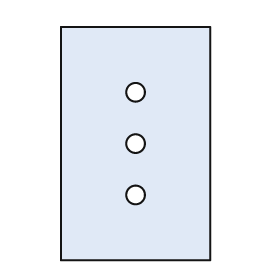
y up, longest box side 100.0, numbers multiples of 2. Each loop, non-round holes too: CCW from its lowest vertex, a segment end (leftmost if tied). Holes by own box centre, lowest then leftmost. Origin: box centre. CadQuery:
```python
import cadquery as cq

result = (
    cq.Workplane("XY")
    .moveTo(-32.0, -50.0)
    .lineTo(32.0, -50.0)
    .lineTo(32.0, 50.0)
    .lineTo(-32.0, 50.0)
    .close()
    .moveTo(0.0, -22.0)
    .circle(4.0)
    .moveTo(0.0, 0.0)
    .circle(4.0)
    .moveTo(0.0, 22.0)
    .circle(4.0)
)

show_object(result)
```